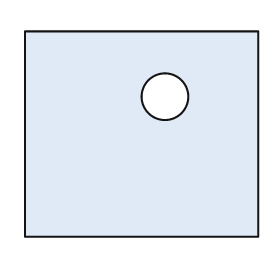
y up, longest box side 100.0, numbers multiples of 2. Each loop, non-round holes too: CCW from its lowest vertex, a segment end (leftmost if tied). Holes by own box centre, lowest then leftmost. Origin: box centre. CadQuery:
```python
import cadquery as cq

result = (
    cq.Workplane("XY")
    .moveTo(-50.0, -44.0)
    .lineTo(50.0, -44.0)
    .lineTo(50.0, 44.0)
    .lineTo(-50.0, 44.0)
    .close()
    .moveTo(10.0, 16.0)
    .circle(10.0)
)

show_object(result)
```